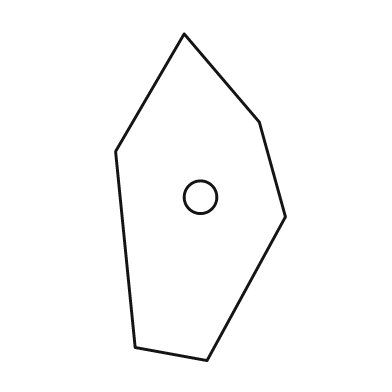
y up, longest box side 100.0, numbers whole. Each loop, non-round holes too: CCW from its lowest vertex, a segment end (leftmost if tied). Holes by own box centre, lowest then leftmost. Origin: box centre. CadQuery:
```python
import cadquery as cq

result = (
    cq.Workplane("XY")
    .moveTo(2.0, -50.0)
    .lineTo(26.0, -6.0)
    .lineTo(18.0, 23.0)
    .lineTo(-5.0, 50.0)
    .lineTo(-26.0, 14.0)
    .lineTo(-20.0, -46.0)
    .close()
    .moveTo(0.0, 0.0)
    .circle(5.0)
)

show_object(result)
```